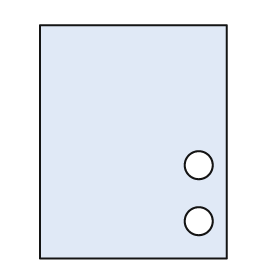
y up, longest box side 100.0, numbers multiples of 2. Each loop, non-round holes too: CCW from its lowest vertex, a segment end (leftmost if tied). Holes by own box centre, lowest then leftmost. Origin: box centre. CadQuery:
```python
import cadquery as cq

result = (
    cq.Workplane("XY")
    .moveTo(-40.0, -50.0)
    .lineTo(40.0, -50.0)
    .lineTo(40.0, 50.0)
    .lineTo(-40.0, 50.0)
    .close()
    .moveTo(28.0, -34.0)
    .circle(6.0)
    .moveTo(28.0, -10.0)
    .circle(6.0)
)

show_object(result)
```